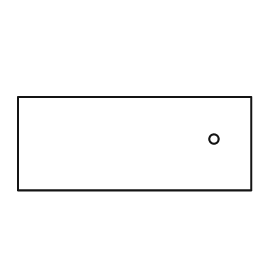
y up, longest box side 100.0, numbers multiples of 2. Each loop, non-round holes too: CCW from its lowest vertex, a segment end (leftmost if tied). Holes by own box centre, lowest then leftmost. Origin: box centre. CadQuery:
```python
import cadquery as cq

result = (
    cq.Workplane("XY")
    .moveTo(-50.0, -20.0)
    .lineTo(50.0, -20.0)
    .lineTo(50.0, 20.0)
    .lineTo(-50.0, 20.0)
    .close()
    .moveTo(34.0, 2.0)
    .circle(2.0)
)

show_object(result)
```